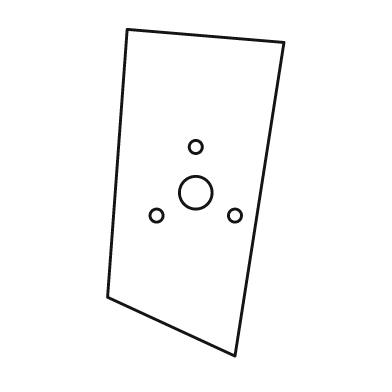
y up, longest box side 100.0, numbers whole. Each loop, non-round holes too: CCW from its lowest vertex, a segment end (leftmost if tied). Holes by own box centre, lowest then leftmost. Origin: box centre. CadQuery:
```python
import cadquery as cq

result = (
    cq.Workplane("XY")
    .moveTo(12.0, -50.0)
    .lineTo(27.0, 46.0)
    .lineTo(-21.0, 50.0)
    .lineTo(-27.0, -32.0)
    .close()
    .moveTo(-12.0, -7.0)
    .circle(2.0)
    .moveTo(12.0, -7.0)
    .circle(2.0)
    .moveTo(0.0, 0.0)
    .circle(5.0)
    .moveTo(0.0, 14.0)
    .circle(2.0)
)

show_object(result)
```